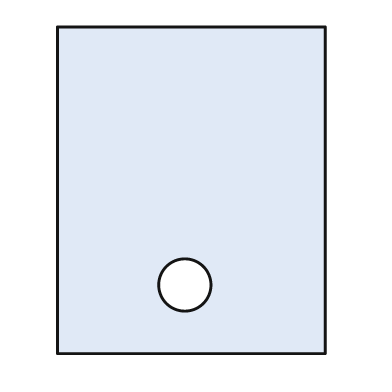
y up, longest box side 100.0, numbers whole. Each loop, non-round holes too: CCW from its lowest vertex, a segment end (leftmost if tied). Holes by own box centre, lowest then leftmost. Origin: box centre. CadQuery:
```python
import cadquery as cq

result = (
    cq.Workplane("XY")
    .moveTo(-41.0, -50.0)
    .lineTo(41.0, -50.0)
    .lineTo(41.0, 50.0)
    .lineTo(-41.0, 50.0)
    .close()
    .moveTo(-2.0, -29.0)
    .circle(8.0)
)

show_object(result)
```